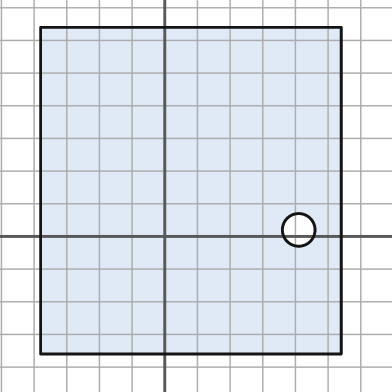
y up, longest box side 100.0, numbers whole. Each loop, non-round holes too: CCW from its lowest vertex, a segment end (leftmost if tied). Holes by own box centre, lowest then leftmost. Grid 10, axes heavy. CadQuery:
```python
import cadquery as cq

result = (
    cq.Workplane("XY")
    .moveTo(-38.0, -36.0)
    .lineTo(54.0, -36.0)
    .lineTo(54.0, 64.0)
    .lineTo(-38.0, 64.0)
    .close()
    .moveTo(41.0, 2.0)
    .circle(5.0)
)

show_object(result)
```